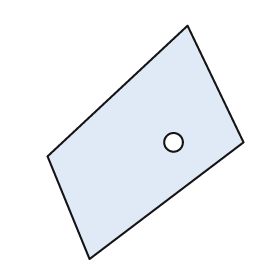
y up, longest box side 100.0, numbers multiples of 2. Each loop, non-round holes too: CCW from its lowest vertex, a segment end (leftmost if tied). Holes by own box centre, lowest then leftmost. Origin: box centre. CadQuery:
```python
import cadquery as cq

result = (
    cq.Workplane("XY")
    .moveTo(-24.0, -50.0)
    .lineTo(42.0, 0.0)
    .lineTo(18.0, 50.0)
    .lineTo(-42.0, -6.0)
    .close()
    .moveTo(12.0, 0.0)
    .circle(4.0)
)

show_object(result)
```